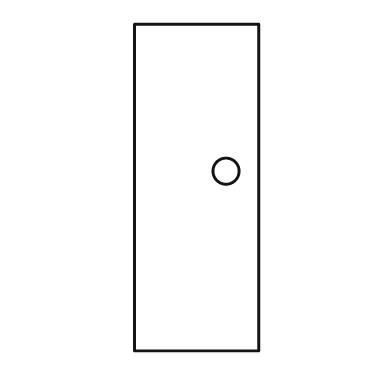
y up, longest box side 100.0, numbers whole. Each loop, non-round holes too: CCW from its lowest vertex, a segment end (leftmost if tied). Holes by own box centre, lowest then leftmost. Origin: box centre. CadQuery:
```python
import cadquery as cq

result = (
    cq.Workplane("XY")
    .moveTo(-19.0, -50.0)
    .lineTo(19.0, -50.0)
    .lineTo(19.0, 50.0)
    .lineTo(-19.0, 50.0)
    .close()
    .moveTo(9.0, 5.0)
    .circle(4.0)
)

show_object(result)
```